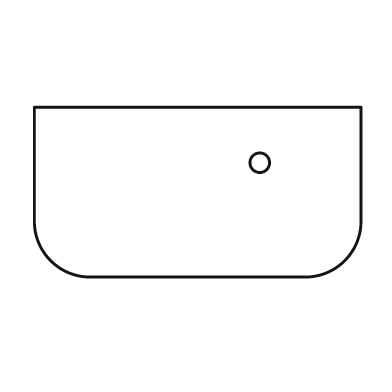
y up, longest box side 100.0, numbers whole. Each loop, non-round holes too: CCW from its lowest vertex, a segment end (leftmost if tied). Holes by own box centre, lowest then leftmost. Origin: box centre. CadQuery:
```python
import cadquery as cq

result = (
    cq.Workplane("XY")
    .moveTo(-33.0, -26.0)
    .lineTo(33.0, -26.0)
    .threePointArc((45.0, -21.0), (50.0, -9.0))
    .lineTo(50.0, 26.0)
    .lineTo(-50.0, 26.0)
    .lineTo(-50.0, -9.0)
    .threePointArc((-45.0, -21.0), (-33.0, -26.0))
    .close()
    .moveTo(19.0, 9.0)
    .circle(3.0)
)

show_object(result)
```